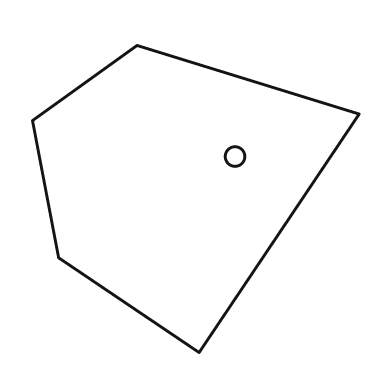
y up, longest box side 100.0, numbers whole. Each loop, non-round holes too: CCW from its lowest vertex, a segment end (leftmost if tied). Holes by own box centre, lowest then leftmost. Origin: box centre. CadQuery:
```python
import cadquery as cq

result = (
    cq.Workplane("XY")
    .moveTo(1.0, -47.0)
    .lineTo(50.0, 26.0)
    .lineTo(-18.0, 47.0)
    .lineTo(-50.0, 24.0)
    .lineTo(-42.0, -18.0)
    .close()
    .moveTo(12.0, 13.0)
    .circle(3.0)
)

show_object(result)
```